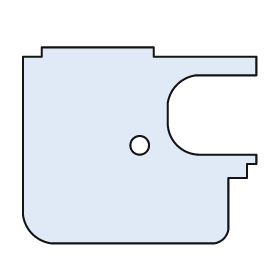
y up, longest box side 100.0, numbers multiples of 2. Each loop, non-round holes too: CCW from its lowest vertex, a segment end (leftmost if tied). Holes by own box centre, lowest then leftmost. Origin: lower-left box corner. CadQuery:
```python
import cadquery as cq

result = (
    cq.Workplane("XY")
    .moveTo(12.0, 0.0)
    .lineTo(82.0, 0.0)
    .threePointArc((86.0, 2.0), (88.0, 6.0))
    .lineTo(88.0, 28.0)
    .lineTo(96.0, 28.0)
    .lineTo(96.0, 34.0)
    .lineTo(100.0, 34.0)
    .lineTo(100.0, 38.0)
    .lineTo(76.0, 38.0)
    .threePointArc((66.0, 42.0), (62.0, 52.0))
    .lineTo(62.0, 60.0)
    .threePointArc((66.0, 68.0), (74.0, 72.0))
    .lineTo(100.0, 72.0)
    .lineTo(100.0, 80.0)
    .lineTo(56.0, 80.0)
    .lineTo(56.0, 84.0)
    .lineTo(8.0, 84.0)
    .lineTo(8.0, 80.0)
    .lineTo(0.0, 80.0)
    .lineTo(0.0, 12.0)
    .threePointArc((4.0, 4.0), (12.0, 0.0))
    .close()
    .moveTo(50.0, 42.0)
    .circle(4.0)
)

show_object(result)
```